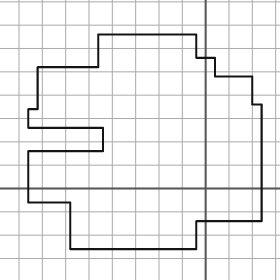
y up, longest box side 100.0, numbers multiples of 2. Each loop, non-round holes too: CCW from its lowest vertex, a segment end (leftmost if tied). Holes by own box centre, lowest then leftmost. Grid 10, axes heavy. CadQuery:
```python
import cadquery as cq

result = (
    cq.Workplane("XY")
    .moveTo(-58.0, -26.0)
    .lineTo(-4.0, -26.0)
    .lineTo(-4.0, -14.0)
    .lineTo(24.0, -14.0)
    .lineTo(24.0, 36.0)
    .lineTo(20.0, 36.0)
    .lineTo(20.0, 48.0)
    .lineTo(4.0, 48.0)
    .lineTo(4.0, 56.0)
    .lineTo(-4.0, 56.0)
    .lineTo(-4.0, 66.0)
    .lineTo(-46.0, 66.0)
    .lineTo(-46.0, 52.0)
    .lineTo(-72.0, 52.0)
    .lineTo(-72.0, 34.0)
    .lineTo(-76.0, 34.0)
    .lineTo(-76.0, 26.0)
    .lineTo(-44.0, 26.0)
    .lineTo(-44.0, 16.0)
    .lineTo(-76.0, 16.0)
    .lineTo(-76.0, -6.0)
    .lineTo(-58.0, -6.0)
    .close()
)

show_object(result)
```